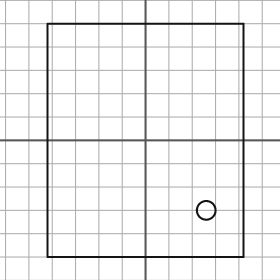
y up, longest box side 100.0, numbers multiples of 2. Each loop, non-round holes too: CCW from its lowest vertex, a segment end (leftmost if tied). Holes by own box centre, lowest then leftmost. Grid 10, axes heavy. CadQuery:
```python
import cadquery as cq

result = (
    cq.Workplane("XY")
    .moveTo(-42.0, -50.0)
    .lineTo(42.0, -50.0)
    .lineTo(42.0, 50.0)
    .lineTo(-42.0, 50.0)
    .close()
    .moveTo(26.0, -30.0)
    .circle(4.0)
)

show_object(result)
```